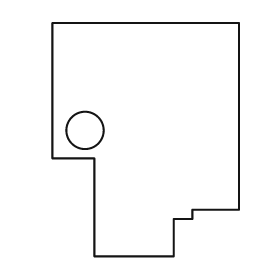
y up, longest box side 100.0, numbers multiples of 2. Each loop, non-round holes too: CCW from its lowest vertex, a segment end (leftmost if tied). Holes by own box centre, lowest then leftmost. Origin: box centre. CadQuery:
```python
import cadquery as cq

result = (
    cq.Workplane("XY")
    .moveTo(-22.0, -50.0)
    .lineTo(12.0, -50.0)
    .lineTo(12.0, -34.0)
    .lineTo(20.0, -34.0)
    .lineTo(20.0, -30.0)
    .lineTo(40.0, -30.0)
    .lineTo(40.0, 50.0)
    .lineTo(-40.0, 50.0)
    .lineTo(-40.0, -8.0)
    .lineTo(-22.0, -8.0)
    .close()
    .moveTo(-26.0, 4.0)
    .circle(8.0)
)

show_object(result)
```